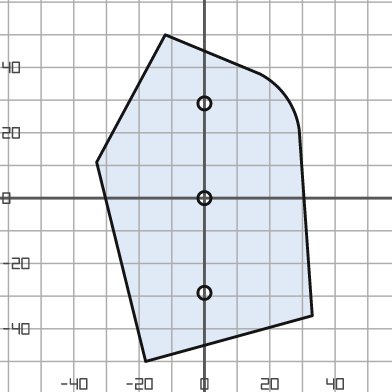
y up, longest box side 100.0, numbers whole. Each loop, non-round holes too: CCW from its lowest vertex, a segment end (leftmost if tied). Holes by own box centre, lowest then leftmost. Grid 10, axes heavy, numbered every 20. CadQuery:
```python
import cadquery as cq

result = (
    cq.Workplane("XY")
    .moveTo(-18.0, -50.0)
    .lineTo(33.0, -36.0)
    .lineTo(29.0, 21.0)
    .threePointArc((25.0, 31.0), (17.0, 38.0))
    .lineTo(-12.0, 50.0)
    .lineTo(-33.0, 11.0)
    .close()
    .moveTo(0.0, -29.0)
    .circle(2.0)
    .moveTo(0.0, 0.0)
    .circle(2.0)
    .moveTo(0.0, 29.0)
    .circle(2.0)
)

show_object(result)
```